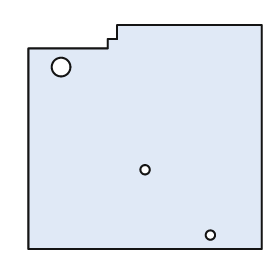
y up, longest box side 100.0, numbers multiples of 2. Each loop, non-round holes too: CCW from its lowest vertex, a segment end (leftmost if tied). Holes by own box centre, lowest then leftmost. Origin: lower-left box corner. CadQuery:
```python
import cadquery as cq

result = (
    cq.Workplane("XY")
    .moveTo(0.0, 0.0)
    .lineTo(100.0, 0.0)
    .lineTo(100.0, 96.0)
    .lineTo(38.0, 96.0)
    .lineTo(38.0, 90.0)
    .lineTo(34.0, 90.0)
    .lineTo(34.0, 86.0)
    .lineTo(0.0, 86.0)
    .close()
    .moveTo(78.0, 6.0)
    .circle(2.0)
    .moveTo(50.0, 34.0)
    .circle(2.0)
    .moveTo(14.0, 78.0)
    .circle(4.0)
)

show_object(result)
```